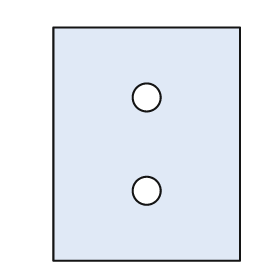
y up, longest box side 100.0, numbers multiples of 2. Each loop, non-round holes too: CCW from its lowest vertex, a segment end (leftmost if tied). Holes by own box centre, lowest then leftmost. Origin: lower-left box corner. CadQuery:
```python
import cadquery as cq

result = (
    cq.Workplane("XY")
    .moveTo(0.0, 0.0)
    .lineTo(80.0, 0.0)
    .lineTo(80.0, 100.0)
    .lineTo(0.0, 100.0)
    .close()
    .moveTo(40.0, 30.0)
    .circle(6.0)
    .moveTo(40.0, 70.0)
    .circle(6.0)
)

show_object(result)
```